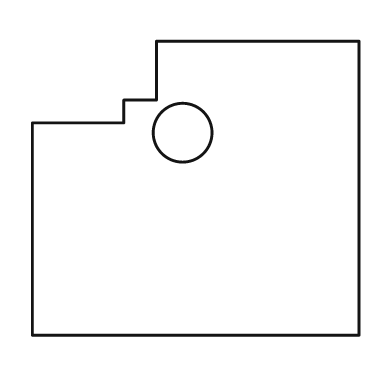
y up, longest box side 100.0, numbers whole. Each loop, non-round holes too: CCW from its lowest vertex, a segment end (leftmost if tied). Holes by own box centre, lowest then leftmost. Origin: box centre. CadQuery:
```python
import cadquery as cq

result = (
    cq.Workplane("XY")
    .moveTo(-50.0, -45.0)
    .lineTo(50.0, -45.0)
    .lineTo(50.0, 45.0)
    .lineTo(-12.0, 45.0)
    .lineTo(-12.0, 27.0)
    .lineTo(-22.0, 27.0)
    .lineTo(-22.0, 20.0)
    .lineTo(-50.0, 20.0)
    .close()
    .moveTo(-4.0, 17.0)
    .circle(9.0)
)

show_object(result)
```